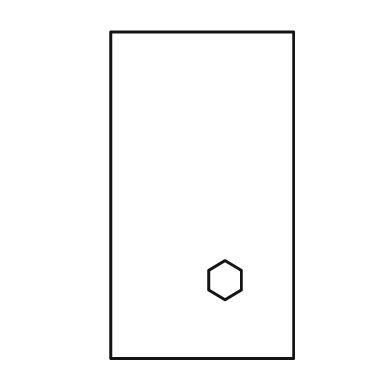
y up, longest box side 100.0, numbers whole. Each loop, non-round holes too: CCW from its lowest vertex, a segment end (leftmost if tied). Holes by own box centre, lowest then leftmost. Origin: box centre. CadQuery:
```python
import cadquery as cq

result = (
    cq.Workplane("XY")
    .moveTo(-28.0, -50.0)
    .lineTo(28.0, -50.0)
    .lineTo(28.0, 50.0)
    .lineTo(-28.0, 50.0)
    .close()
    .moveTo(7.0, -32.0)
    .lineTo(12.0, -29.0)
    .lineTo(12.0, -23.0)
    .lineTo(7.0, -20.0)
    .lineTo(2.0, -23.0)
    .lineTo(2.0, -29.0)
    .close()
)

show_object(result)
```